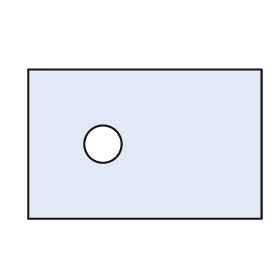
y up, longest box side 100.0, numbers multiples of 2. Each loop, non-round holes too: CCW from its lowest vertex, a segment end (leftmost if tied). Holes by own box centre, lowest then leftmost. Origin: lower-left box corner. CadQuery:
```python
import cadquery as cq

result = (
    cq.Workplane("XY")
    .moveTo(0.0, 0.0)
    .lineTo(100.0, 0.0)
    .lineTo(100.0, 64.0)
    .lineTo(0.0, 64.0)
    .close()
    .moveTo(32.0, 32.0)
    .circle(8.0)
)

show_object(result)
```